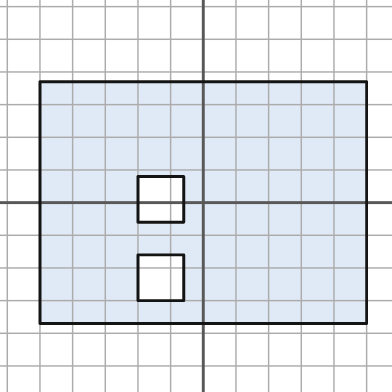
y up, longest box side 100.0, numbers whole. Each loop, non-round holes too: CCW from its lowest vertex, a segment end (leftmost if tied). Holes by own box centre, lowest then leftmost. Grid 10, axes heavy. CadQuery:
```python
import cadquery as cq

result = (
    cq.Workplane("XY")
    .moveTo(-50.0, -37.0)
    .lineTo(50.0, -37.0)
    .lineTo(50.0, 37.0)
    .lineTo(-50.0, 37.0)
    .close()
    .moveTo(-20.0, -30.0)
    .lineTo(-6.0, -30.0)
    .lineTo(-6.0, -16.0)
    .lineTo(-20.0, -16.0)
    .close()
    .moveTo(-20.0, -6.0)
    .lineTo(-6.0, -6.0)
    .lineTo(-6.0, 8.0)
    .lineTo(-20.0, 8.0)
    .close()
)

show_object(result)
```